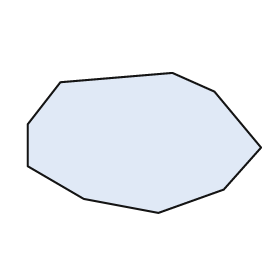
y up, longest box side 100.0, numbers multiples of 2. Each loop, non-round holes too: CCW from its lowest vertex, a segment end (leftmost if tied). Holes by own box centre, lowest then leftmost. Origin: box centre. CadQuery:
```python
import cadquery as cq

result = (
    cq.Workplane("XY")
    .moveTo(6.0, -30.0)
    .lineTo(34.0, -20.0)
    .lineTo(50.0, -2.0)
    .lineTo(30.0, 22.0)
    .lineTo(12.0, 30.0)
    .lineTo(-36.0, 26.0)
    .lineTo(-50.0, 8.0)
    .lineTo(-50.0, -10.0)
    .lineTo(-26.0, -24.0)
    .close()
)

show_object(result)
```